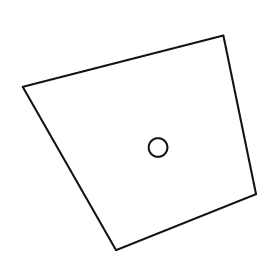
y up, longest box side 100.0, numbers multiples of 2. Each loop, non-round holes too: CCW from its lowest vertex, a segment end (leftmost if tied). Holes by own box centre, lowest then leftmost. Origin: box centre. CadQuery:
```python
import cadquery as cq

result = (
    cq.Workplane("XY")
    .moveTo(-10.0, -46.0)
    .lineTo(50.0, -22.0)
    .lineTo(36.0, 46.0)
    .lineTo(-50.0, 24.0)
    .close()
    .moveTo(8.0, -2.0)
    .circle(4.0)
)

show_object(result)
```